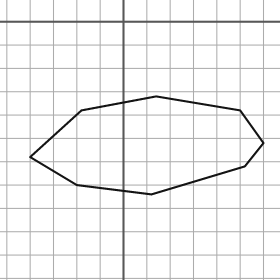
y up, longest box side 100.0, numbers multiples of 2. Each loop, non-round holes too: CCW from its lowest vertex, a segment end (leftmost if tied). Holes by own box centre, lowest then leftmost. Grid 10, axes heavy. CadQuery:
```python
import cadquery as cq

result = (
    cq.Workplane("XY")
    .moveTo(12.0, -74.0)
    .lineTo(52.0, -62.0)
    .lineTo(60.0, -52.0)
    .lineTo(50.0, -38.0)
    .lineTo(14.0, -32.0)
    .lineTo(-18.0, -38.0)
    .lineTo(-40.0, -58.0)
    .lineTo(-20.0, -70.0)
    .close()
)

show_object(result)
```